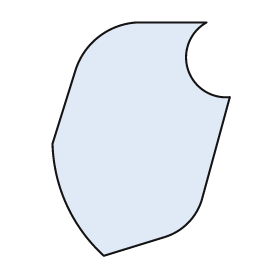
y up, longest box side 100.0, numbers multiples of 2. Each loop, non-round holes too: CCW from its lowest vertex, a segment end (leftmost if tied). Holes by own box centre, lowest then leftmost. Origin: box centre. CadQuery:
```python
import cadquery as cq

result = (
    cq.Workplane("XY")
    .moveTo(-16.0, -50.0)
    .lineTo(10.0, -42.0)
    .threePointArc((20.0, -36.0), (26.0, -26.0))
    .lineTo(38.0, 18.0)
    .threePointArc((20.0, 30.0), (28.0, 50.0))
    .lineTo(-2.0, 50.0)
    .threePointArc((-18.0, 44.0), (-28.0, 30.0))
    .lineTo(-38.0, -2.0)
    .threePointArc((-32.0, -28.0), (-16.0, -50.0))
    .close()
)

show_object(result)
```